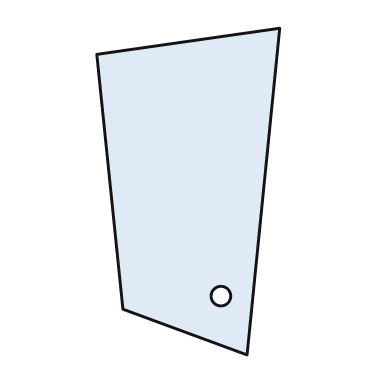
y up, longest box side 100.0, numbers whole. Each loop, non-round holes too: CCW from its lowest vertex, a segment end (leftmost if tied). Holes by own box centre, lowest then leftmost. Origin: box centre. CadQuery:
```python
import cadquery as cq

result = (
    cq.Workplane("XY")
    .moveTo(18.0, -50.0)
    .lineTo(28.0, 50.0)
    .lineTo(-28.0, 42.0)
    .lineTo(-20.0, -36.0)
    .close()
    .moveTo(10.0, -32.0)
    .circle(3.0)
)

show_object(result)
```